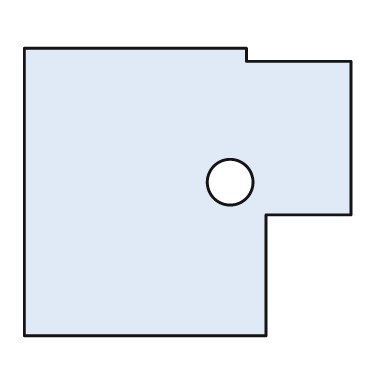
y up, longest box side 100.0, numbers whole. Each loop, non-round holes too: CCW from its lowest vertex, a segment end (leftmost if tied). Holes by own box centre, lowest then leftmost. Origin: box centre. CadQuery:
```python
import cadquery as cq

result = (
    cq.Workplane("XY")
    .moveTo(-50.0, -44.0)
    .lineTo(24.0, -44.0)
    .lineTo(24.0, -7.0)
    .lineTo(50.0, -7.0)
    .lineTo(50.0, 40.0)
    .lineTo(18.0, 40.0)
    .lineTo(18.0, 44.0)
    .lineTo(-50.0, 44.0)
    .close()
    .moveTo(13.0, 3.0)
    .circle(7.0)
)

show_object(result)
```